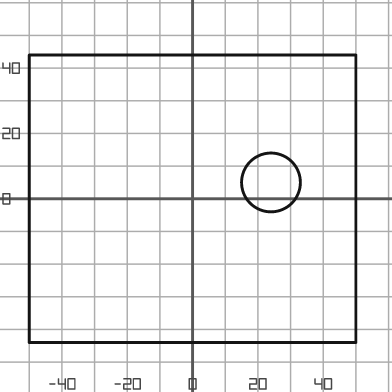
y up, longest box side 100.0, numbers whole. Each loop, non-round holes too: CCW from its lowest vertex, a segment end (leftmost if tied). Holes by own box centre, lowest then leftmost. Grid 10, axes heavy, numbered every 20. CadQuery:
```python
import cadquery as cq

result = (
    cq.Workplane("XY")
    .moveTo(-50.0, -44.0)
    .lineTo(50.0, -44.0)
    .lineTo(50.0, 44.0)
    .lineTo(-50.0, 44.0)
    .close()
    .moveTo(24.0, 5.0)
    .circle(9.0)
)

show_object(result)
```